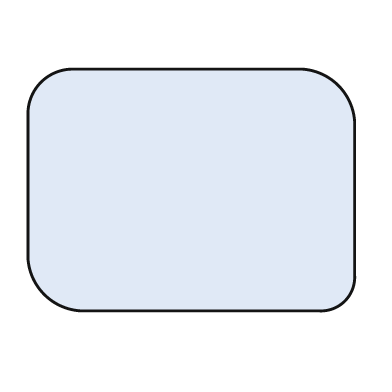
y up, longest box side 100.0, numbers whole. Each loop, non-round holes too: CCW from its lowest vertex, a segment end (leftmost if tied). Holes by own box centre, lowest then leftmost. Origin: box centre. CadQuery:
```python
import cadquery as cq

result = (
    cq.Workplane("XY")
    .moveTo(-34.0, -37.0)
    .lineTo(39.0, -37.0)
    .threePointArc((47.0, -34.0), (50.0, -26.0))
    .lineTo(50.0, 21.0)
    .threePointArc((45.0, 32.0), (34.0, 37.0))
    .lineTo(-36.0, 37.0)
    .threePointArc((-46.0, 33.0), (-50.0, 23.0))
    .lineTo(-50.0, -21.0)
    .threePointArc((-45.0, -32.0), (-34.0, -37.0))
    .close()
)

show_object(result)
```